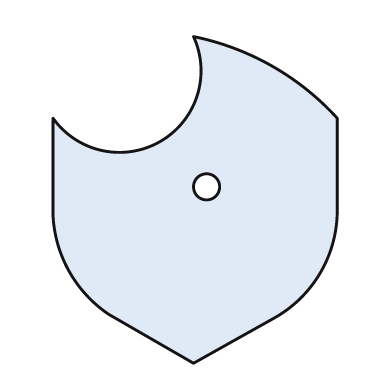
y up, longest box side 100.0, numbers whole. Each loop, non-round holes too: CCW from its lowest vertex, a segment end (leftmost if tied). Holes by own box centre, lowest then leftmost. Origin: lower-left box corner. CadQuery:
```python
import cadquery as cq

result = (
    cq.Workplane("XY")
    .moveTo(43.0, 0.0)
    .lineTo(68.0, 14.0)
    .threePointArc((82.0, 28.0), (87.0, 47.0))
    .lineTo(87.0, 75.0)
    .threePointArc((67.0, 91.0), (43.0, 100.0))
    .threePointArc((33.0, 68.0), (0.0, 75.0))
    .lineTo(0.0, 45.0)
    .threePointArc((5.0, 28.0), (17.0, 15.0))
    .close()
    .moveTo(47.0, 54.0)
    .circle(4.0)
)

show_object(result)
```